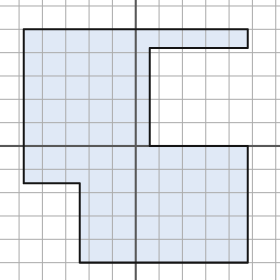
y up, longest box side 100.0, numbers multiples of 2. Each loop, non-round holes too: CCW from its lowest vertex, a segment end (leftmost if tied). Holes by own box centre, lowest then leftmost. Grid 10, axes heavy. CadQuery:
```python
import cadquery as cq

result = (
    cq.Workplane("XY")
    .moveTo(-24.0, -50.0)
    .lineTo(48.0, -50.0)
    .lineTo(48.0, 0.0)
    .lineTo(6.0, 0.0)
    .lineTo(6.0, 42.0)
    .lineTo(48.0, 42.0)
    .lineTo(48.0, 50.0)
    .lineTo(-48.0, 50.0)
    .lineTo(-48.0, -16.0)
    .lineTo(-24.0, -16.0)
    .close()
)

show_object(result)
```